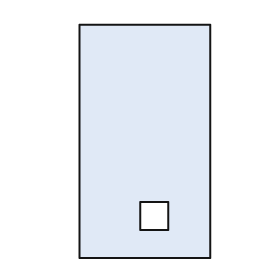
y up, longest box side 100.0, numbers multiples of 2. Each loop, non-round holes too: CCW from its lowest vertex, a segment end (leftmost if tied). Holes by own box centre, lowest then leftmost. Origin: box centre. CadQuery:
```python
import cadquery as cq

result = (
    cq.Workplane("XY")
    .moveTo(-28.0, -50.0)
    .lineTo(28.0, -50.0)
    .lineTo(28.0, 50.0)
    .lineTo(-28.0, 50.0)
    .close()
    .moveTo(-2.0, -38.0)
    .lineTo(10.0, -38.0)
    .lineTo(10.0, -26.0)
    .lineTo(-2.0, -26.0)
    .close()
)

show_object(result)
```